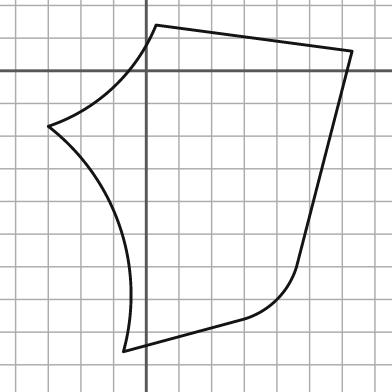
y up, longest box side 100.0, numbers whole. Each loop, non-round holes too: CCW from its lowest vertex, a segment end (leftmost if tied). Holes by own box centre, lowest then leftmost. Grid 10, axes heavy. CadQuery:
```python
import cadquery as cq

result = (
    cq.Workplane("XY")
    .moveTo(-7.0, -86.0)
    .lineTo(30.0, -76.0)
    .threePointArc((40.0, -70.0), (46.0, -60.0))
    .lineTo(63.0, 6.0)
    .lineTo(3.0, 14.0)
    .threePointArc((-10.0, -5.0), (-30.0, -17.0))
    .threePointArc((-8.0, -48.0), (-7.0, -86.0))
    .close()
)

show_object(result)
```